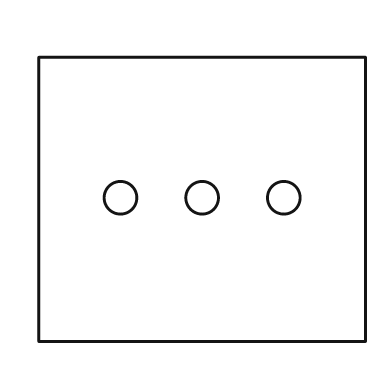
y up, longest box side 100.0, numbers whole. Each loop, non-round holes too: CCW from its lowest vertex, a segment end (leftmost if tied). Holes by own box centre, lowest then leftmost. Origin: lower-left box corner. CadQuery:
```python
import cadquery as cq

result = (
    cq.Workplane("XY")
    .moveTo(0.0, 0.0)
    .lineTo(100.0, 0.0)
    .lineTo(100.0, 87.0)
    .lineTo(0.0, 87.0)
    .close()
    .moveTo(25.0, 44.0)
    .circle(5.0)
    .moveTo(50.0, 44.0)
    .circle(5.0)
    .moveTo(75.0, 44.0)
    .circle(5.0)
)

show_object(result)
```